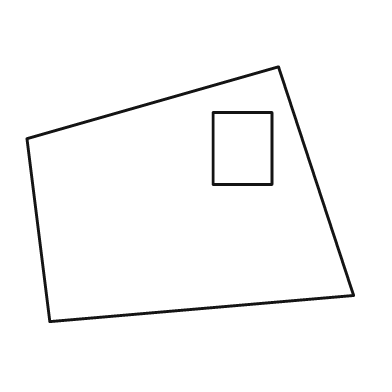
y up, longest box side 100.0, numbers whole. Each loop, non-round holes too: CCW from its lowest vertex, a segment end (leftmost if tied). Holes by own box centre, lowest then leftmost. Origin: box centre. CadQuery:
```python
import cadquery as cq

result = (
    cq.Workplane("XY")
    .moveTo(-43.0, -39.0)
    .lineTo(50.0, -31.0)
    .lineTo(27.0, 39.0)
    .lineTo(-50.0, 17.0)
    .close()
    .moveTo(7.0, 3.0)
    .lineTo(25.0, 3.0)
    .lineTo(25.0, 25.0)
    .lineTo(7.0, 25.0)
    .close()
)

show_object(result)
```